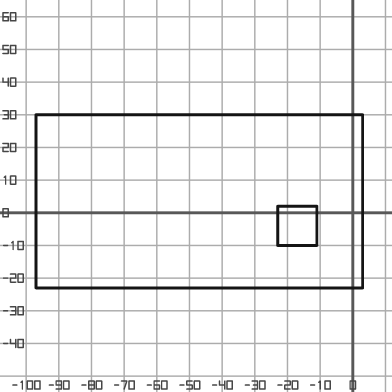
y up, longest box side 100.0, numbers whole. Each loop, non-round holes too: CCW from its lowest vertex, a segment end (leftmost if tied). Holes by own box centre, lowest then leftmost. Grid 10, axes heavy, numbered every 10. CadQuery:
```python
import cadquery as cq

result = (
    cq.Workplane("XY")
    .moveTo(-97.0, -23.0)
    .lineTo(3.0, -23.0)
    .lineTo(3.0, 30.0)
    .lineTo(-97.0, 30.0)
    .close()
    .moveTo(-23.0, -10.0)
    .lineTo(-11.0, -10.0)
    .lineTo(-11.0, 2.0)
    .lineTo(-23.0, 2.0)
    .close()
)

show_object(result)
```